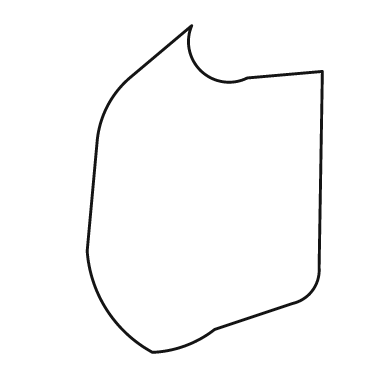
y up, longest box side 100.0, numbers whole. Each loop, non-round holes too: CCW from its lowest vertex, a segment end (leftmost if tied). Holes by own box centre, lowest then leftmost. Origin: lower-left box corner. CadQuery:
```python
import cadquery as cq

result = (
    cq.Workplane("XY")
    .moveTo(20.0, 0.0)
    .threePointArc((30.0, 2.0), (39.0, 7.0))
    .lineTo(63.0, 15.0)
    .threePointArc((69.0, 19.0), (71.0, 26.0))
    .lineTo(72.0, 86.0)
    .lineTo(49.0, 84.0)
    .threePointArc((35.0, 86.0), (32.0, 100.0))
    .lineTo(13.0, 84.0)
    .threePointArc((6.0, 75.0), (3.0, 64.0))
    .lineTo(0.0, 31.0)
    .threePointArc((6.0, 13.0), (20.0, 0.0))
    .close()
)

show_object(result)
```